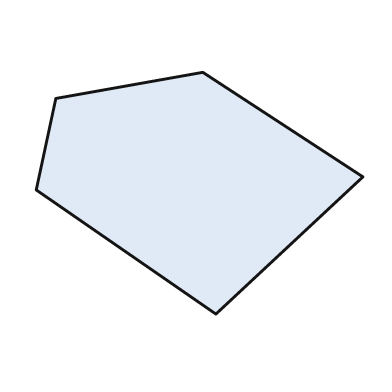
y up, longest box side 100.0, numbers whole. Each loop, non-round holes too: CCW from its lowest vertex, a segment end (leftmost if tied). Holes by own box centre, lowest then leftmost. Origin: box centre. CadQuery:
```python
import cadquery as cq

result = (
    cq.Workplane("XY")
    .moveTo(5.0, -37.0)
    .lineTo(50.0, 5.0)
    .lineTo(1.0, 37.0)
    .lineTo(-44.0, 29.0)
    .lineTo(-50.0, 1.0)
    .close()
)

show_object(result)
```